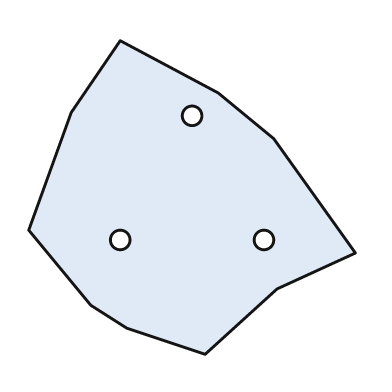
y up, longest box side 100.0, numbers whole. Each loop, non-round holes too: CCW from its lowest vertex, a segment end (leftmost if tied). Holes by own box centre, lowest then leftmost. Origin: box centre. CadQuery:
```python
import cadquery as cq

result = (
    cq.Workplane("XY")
    .moveTo(4.0, -48.0)
    .lineTo(26.0, -28.0)
    .lineTo(50.0, -17.0)
    .lineTo(25.0, 18.0)
    .lineTo(8.0, 32.0)
    .lineTo(-22.0, 48.0)
    .lineTo(-37.0, 26.0)
    .lineTo(-50.0, -10.0)
    .lineTo(-31.0, -33.0)
    .lineTo(-20.0, -40.0)
    .close()
    .moveTo(-22.0, -13.0)
    .circle(3.0)
    .moveTo(22.0, -13.0)
    .circle(3.0)
    .moveTo(0.0, 25.0)
    .circle(3.0)
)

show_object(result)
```